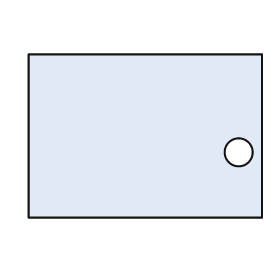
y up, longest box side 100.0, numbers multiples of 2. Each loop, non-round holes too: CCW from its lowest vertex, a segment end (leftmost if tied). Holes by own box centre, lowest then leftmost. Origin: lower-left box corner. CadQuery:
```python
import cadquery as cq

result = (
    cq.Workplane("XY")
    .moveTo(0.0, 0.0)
    .lineTo(100.0, 0.0)
    .lineTo(100.0, 70.0)
    .lineTo(0.0, 70.0)
    .close()
    .moveTo(90.0, 28.0)
    .circle(6.0)
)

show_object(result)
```